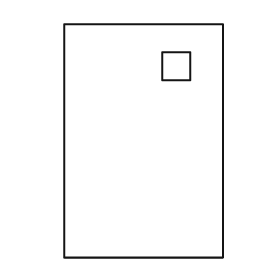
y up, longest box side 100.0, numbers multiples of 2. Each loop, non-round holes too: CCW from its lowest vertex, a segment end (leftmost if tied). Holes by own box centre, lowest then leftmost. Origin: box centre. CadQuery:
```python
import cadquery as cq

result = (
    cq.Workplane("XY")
    .moveTo(-34.0, -50.0)
    .lineTo(34.0, -50.0)
    .lineTo(34.0, 50.0)
    .lineTo(-34.0, 50.0)
    .close()
    .moveTo(8.0, 26.0)
    .lineTo(20.0, 26.0)
    .lineTo(20.0, 38.0)
    .lineTo(8.0, 38.0)
    .close()
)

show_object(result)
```